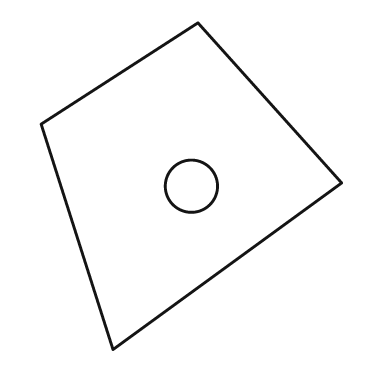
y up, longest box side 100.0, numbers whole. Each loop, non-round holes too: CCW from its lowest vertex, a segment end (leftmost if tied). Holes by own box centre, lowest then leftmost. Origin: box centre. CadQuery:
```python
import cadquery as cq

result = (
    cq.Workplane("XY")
    .moveTo(-24.0, -50.0)
    .lineTo(46.0, 1.0)
    .lineTo(2.0, 50.0)
    .lineTo(-46.0, 19.0)
    .close()
    .moveTo(0.0, 0.0)
    .circle(8.0)
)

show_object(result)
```